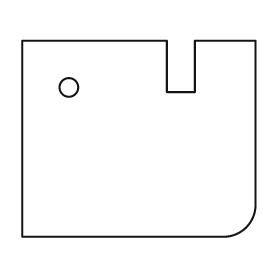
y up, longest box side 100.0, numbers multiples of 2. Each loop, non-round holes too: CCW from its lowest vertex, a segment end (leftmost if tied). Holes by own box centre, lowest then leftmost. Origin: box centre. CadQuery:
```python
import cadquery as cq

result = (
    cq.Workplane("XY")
    .moveTo(-50.0, -42.0)
    .lineTo(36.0, -42.0)
    .threePointArc((46.0, -38.0), (50.0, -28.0))
    .lineTo(50.0, 42.0)
    .lineTo(24.0, 42.0)
    .lineTo(24.0, 20.0)
    .lineTo(12.0, 20.0)
    .lineTo(12.0, 42.0)
    .lineTo(-50.0, 42.0)
    .close()
    .moveTo(-30.0, 22.0)
    .circle(4.0)
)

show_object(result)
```